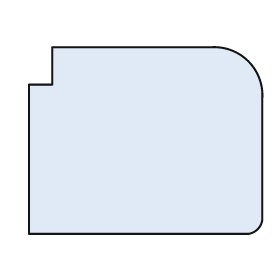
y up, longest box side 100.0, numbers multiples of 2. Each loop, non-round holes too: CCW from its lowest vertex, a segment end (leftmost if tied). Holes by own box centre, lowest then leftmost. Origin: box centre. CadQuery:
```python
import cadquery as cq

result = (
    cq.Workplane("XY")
    .moveTo(-50.0, -40.0)
    .lineTo(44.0, -40.0)
    .threePointArc((48.0, -38.0), (50.0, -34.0))
    .lineTo(50.0, 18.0)
    .threePointArc((44.0, 34.0), (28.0, 40.0))
    .lineTo(-40.0, 40.0)
    .lineTo(-40.0, 24.0)
    .lineTo(-50.0, 24.0)
    .close()
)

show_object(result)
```